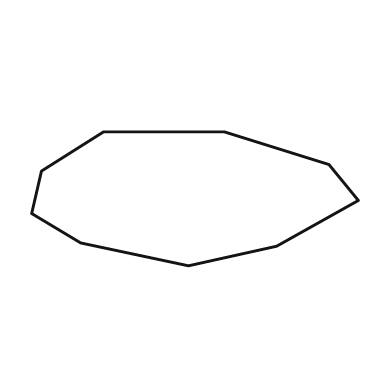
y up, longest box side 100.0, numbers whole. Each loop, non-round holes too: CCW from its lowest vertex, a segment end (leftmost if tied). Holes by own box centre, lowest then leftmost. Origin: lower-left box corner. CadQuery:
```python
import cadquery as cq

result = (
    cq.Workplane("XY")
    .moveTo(48.0, 0.0)
    .lineTo(75.0, 6.0)
    .lineTo(100.0, 20.0)
    .lineTo(91.0, 31.0)
    .lineTo(59.0, 41.0)
    .lineTo(22.0, 41.0)
    .lineTo(3.0, 29.0)
    .lineTo(0.0, 16.0)
    .lineTo(15.0, 7.0)
    .close()
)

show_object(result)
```